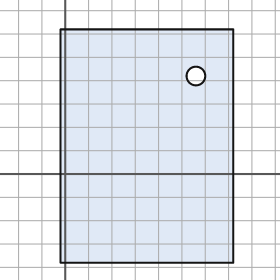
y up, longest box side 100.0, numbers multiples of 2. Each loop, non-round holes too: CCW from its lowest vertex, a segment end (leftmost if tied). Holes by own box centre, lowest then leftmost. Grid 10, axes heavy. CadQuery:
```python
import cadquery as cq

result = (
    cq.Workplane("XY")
    .moveTo(-2.0, -38.0)
    .lineTo(72.0, -38.0)
    .lineTo(72.0, 62.0)
    .lineTo(-2.0, 62.0)
    .close()
    .moveTo(56.0, 42.0)
    .circle(4.0)
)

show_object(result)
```